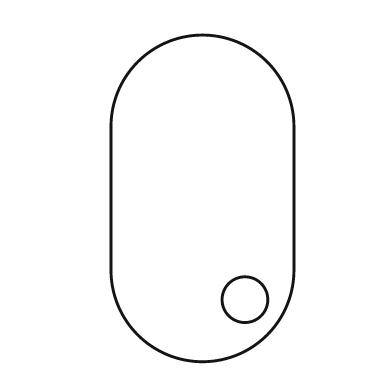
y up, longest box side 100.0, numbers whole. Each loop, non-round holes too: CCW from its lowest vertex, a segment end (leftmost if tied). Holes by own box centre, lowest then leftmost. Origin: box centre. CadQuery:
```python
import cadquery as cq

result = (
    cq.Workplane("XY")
    .moveTo(-28.0, -22.0)
    .threePointArc((0.0, -50.0), (28.0, -22.0))
    .lineTo(28.0, 22.0)
    .threePointArc((0.0, 50.0), (-28.0, 22.0))
    .close()
    .moveTo(13.0, -31.0)
    .circle(7.0)
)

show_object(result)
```